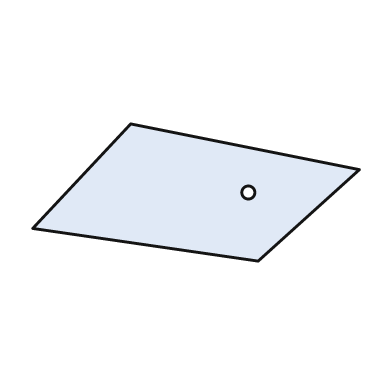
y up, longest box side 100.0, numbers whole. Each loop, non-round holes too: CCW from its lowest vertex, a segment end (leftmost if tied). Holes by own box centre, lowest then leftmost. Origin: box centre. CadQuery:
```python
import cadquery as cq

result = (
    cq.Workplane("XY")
    .moveTo(19.0, -21.0)
    .lineTo(50.0, 7.0)
    .lineTo(-20.0, 21.0)
    .lineTo(-50.0, -11.0)
    .close()
    .moveTo(16.0, 0.0)
    .circle(2.0)
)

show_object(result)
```